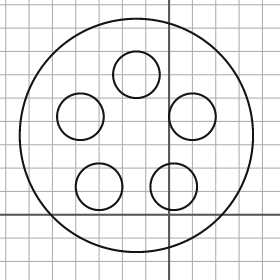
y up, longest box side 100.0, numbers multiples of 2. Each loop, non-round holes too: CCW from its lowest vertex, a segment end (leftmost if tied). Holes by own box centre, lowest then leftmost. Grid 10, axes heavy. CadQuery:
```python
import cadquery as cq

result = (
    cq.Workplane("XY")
    .moveTo(-14.0, 34.0)
    .circle(50.0)
    .moveTo(-30.0, 12.0)
    .circle(10.0)
    .moveTo(2.0, 12.0)
    .circle(10.0)
    .moveTo(-38.0, 42.0)
    .circle(10.0)
    .moveTo(10.0, 42.0)
    .circle(10.0)
    .moveTo(-14.0, 60.0)
    .circle(10.0)
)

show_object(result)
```